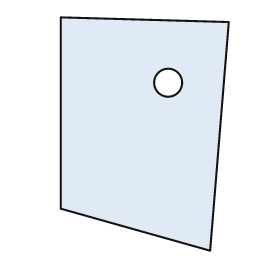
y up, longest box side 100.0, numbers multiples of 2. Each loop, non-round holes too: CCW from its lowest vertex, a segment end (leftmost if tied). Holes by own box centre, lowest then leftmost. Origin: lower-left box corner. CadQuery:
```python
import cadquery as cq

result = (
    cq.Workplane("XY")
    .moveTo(64.0, 0.0)
    .lineTo(72.0, 98.0)
    .lineTo(0.0, 100.0)
    .lineTo(0.0, 18.0)
    .close()
    .moveTo(46.0, 72.0)
    .circle(6.0)
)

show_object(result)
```